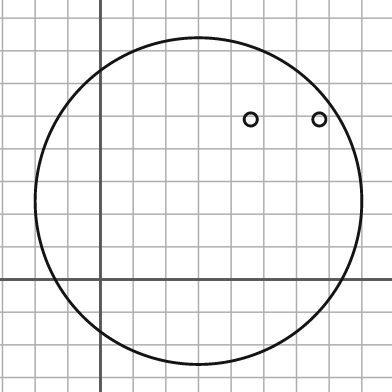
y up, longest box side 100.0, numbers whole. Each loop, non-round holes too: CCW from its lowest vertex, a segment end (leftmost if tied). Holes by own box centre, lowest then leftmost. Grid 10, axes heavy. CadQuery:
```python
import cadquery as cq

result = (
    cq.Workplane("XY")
    .moveTo(30.0, 24.0)
    .circle(50.0)
    .moveTo(46.0, 49.0)
    .circle(2.0)
    .moveTo(67.0, 49.0)
    .circle(2.0)
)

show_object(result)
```